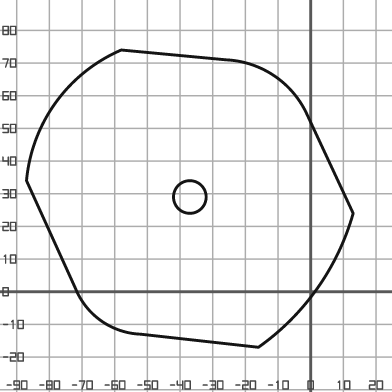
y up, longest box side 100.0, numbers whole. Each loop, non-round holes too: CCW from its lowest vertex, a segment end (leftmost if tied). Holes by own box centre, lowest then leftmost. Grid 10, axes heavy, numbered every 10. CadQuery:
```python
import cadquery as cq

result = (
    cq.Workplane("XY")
    .moveTo(-16.0, -17.0)
    .threePointArc((2.0, 1.0), (13.0, 24.0))
    .lineTo(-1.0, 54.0)
    .threePointArc((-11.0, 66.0), (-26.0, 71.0))
    .lineTo(-58.0, 74.0)
    .threePointArc((-78.0, 58.0), (-87.0, 34.0))
    .lineTo(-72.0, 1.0)
    .threePointArc((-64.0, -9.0), (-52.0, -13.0))
    .close()
    .moveTo(-37.0, 29.0)
    .circle(5.0)
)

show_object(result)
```